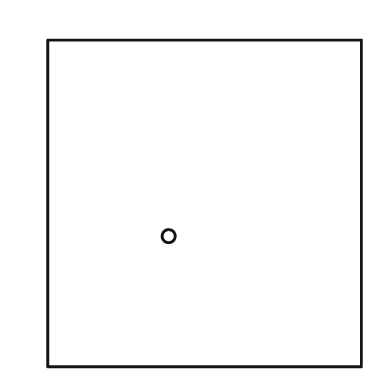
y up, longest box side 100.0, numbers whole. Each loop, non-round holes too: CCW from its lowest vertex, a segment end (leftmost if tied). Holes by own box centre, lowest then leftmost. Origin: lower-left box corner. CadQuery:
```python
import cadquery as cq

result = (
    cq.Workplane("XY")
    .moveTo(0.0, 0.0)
    .lineTo(96.0, 0.0)
    .lineTo(96.0, 100.0)
    .lineTo(0.0, 100.0)
    .close()
    .moveTo(37.0, 40.0)
    .circle(2.0)
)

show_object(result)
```